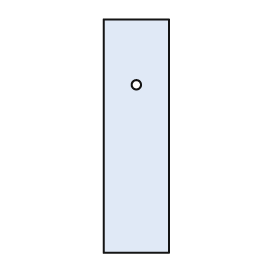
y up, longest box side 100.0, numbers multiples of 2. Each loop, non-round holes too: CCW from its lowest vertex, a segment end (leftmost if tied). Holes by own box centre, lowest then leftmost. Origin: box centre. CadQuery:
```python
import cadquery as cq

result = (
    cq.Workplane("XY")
    .moveTo(-14.0, -50.0)
    .lineTo(14.0, -50.0)
    .lineTo(14.0, 50.0)
    .lineTo(-14.0, 50.0)
    .close()
    .moveTo(0.0, 22.0)
    .circle(2.0)
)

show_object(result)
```